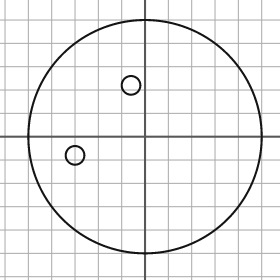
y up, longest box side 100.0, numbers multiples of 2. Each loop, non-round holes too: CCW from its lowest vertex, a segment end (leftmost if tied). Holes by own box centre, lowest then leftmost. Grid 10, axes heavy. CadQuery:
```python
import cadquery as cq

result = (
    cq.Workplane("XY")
    .moveTo(0.0, 0.0)
    .circle(50.0)
    .moveTo(-30.0, -8.0)
    .circle(4.0)
    .moveTo(-6.0, 22.0)
    .circle(4.0)
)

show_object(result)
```